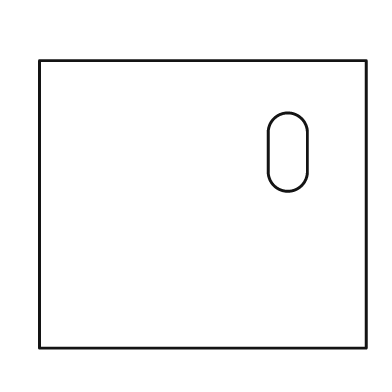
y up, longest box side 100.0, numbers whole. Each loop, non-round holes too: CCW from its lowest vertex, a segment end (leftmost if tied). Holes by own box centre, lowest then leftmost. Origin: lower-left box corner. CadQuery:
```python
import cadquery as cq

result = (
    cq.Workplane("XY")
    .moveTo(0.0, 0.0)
    .lineTo(100.0, 0.0)
    .lineTo(100.0, 88.0)
    .lineTo(0.0, 88.0)
    .close()
    .moveTo(70.0, 54.0)
    .threePointArc((76.0, 48.0), (82.0, 54.0))
    .lineTo(82.0, 66.0)
    .threePointArc((76.0, 72.0), (70.0, 66.0))
    .close()
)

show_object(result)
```